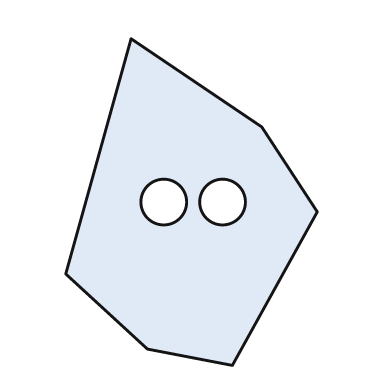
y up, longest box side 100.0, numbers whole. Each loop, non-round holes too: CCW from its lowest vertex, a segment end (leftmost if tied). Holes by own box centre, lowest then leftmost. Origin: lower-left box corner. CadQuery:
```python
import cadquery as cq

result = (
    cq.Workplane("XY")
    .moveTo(51.0, 0.0)
    .lineTo(77.0, 47.0)
    .lineTo(60.0, 73.0)
    .lineTo(20.0, 100.0)
    .lineTo(0.0, 28.0)
    .lineTo(25.0, 5.0)
    .close()
    .moveTo(30.0, 50.0)
    .circle(7.0)
    .moveTo(48.0, 50.0)
    .circle(7.0)
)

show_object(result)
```